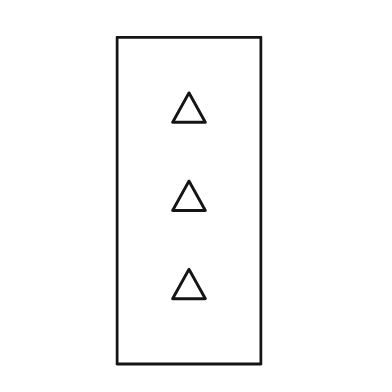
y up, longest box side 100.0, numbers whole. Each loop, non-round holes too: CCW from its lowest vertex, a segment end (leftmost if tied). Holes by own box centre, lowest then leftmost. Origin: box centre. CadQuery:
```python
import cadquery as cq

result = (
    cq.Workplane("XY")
    .moveTo(-22.0, -50.0)
    .lineTo(22.0, -50.0)
    .lineTo(22.0, 50.0)
    .lineTo(-22.0, 50.0)
    .close()
    .moveTo(-5.0, -30.0)
    .lineTo(5.0, -30.0)
    .lineTo(0.0, -21.0)
    .close()
    .moveTo(-5.0, -3.0)
    .lineTo(5.0, -3.0)
    .lineTo(0.0, 6.0)
    .close()
    .moveTo(-5.0, 24.0)
    .lineTo(5.0, 24.0)
    .lineTo(0.0, 33.0)
    .close()
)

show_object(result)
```